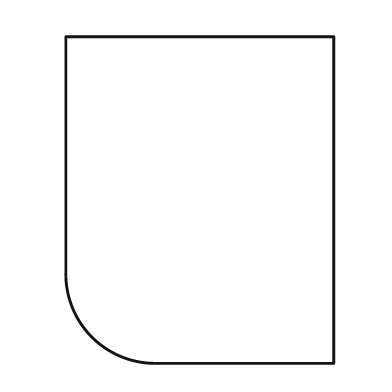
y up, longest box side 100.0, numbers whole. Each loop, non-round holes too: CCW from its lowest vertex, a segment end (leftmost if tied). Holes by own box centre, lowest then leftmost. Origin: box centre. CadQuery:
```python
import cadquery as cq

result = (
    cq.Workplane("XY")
    .moveTo(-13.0, -50.0)
    .lineTo(41.0, -50.0)
    .lineTo(41.0, 50.0)
    .lineTo(-41.0, 50.0)
    .lineTo(-41.0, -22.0)
    .threePointArc((-33.0, -42.0), (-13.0, -50.0))
    .close()
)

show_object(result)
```